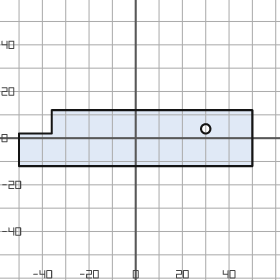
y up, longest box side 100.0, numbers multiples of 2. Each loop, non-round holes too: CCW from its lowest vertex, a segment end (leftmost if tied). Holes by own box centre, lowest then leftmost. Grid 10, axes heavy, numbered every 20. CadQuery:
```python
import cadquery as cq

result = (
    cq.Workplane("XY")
    .moveTo(-50.0, -12.0)
    .lineTo(50.0, -12.0)
    .lineTo(50.0, 12.0)
    .lineTo(-36.0, 12.0)
    .lineTo(-36.0, 2.0)
    .lineTo(-50.0, 2.0)
    .close()
    .moveTo(30.0, 4.0)
    .circle(2.0)
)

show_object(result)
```